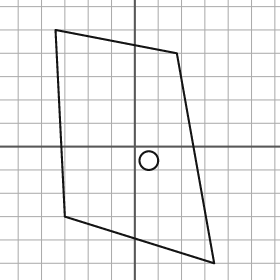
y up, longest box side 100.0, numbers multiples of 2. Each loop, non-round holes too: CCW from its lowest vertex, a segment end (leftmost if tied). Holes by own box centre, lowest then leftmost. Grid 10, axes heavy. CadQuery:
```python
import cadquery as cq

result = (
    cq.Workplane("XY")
    .moveTo(34.0, -50.0)
    .lineTo(18.0, 40.0)
    .lineTo(-34.0, 50.0)
    .lineTo(-30.0, -30.0)
    .close()
    .moveTo(6.0, -6.0)
    .circle(4.0)
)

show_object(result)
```